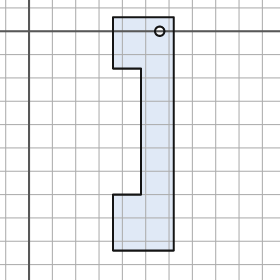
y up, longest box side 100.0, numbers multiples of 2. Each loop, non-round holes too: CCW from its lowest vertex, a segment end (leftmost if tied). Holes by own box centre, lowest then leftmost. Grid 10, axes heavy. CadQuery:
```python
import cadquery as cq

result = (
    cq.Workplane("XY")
    .moveTo(36.0, -94.0)
    .lineTo(62.0, -94.0)
    .lineTo(62.0, 6.0)
    .lineTo(36.0, 6.0)
    .lineTo(36.0, -16.0)
    .lineTo(48.0, -16.0)
    .lineTo(48.0, -70.0)
    .lineTo(36.0, -70.0)
    .close()
    .moveTo(56.0, 0.0)
    .circle(2.0)
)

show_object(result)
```